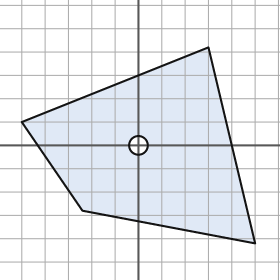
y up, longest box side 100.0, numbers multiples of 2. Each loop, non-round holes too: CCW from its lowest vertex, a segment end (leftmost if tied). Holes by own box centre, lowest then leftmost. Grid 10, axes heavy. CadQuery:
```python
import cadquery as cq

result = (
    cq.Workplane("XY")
    .moveTo(50.0, -42.0)
    .lineTo(30.0, 42.0)
    .lineTo(-50.0, 10.0)
    .lineTo(-24.0, -28.0)
    .close()
    .moveTo(0.0, 0.0)
    .circle(4.0)
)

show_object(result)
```